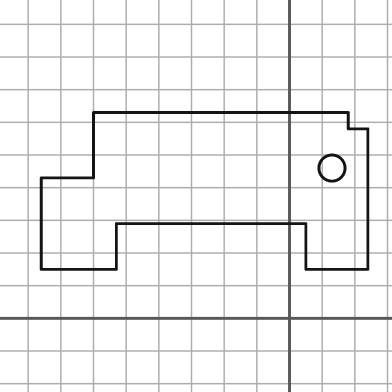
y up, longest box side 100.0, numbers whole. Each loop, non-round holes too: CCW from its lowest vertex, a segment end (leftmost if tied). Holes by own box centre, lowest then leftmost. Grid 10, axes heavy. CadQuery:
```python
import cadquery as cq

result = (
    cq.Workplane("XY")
    .moveTo(-76.0, 15.0)
    .lineTo(-53.0, 15.0)
    .lineTo(-53.0, 29.0)
    .lineTo(5.0, 29.0)
    .lineTo(5.0, 15.0)
    .lineTo(24.0, 15.0)
    .lineTo(24.0, 58.0)
    .lineTo(18.0, 58.0)
    .lineTo(18.0, 63.0)
    .lineTo(-60.0, 63.0)
    .lineTo(-60.0, 43.0)
    .lineTo(-76.0, 43.0)
    .close()
    .moveTo(13.0, 46.0)
    .circle(4.0)
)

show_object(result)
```